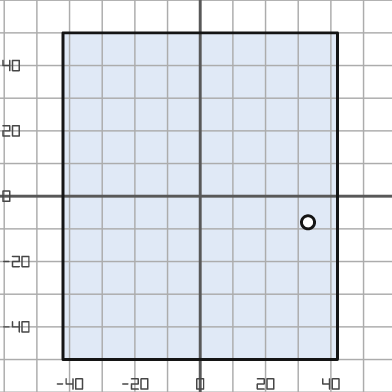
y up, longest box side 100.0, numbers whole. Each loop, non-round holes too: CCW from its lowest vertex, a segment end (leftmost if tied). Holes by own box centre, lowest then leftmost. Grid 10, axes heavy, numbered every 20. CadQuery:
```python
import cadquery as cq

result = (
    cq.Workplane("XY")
    .moveTo(-42.0, -50.0)
    .lineTo(42.0, -50.0)
    .lineTo(42.0, 50.0)
    .lineTo(-42.0, 50.0)
    .close()
    .moveTo(33.0, -8.0)
    .circle(2.0)
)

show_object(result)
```